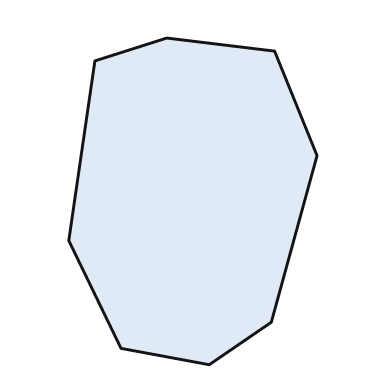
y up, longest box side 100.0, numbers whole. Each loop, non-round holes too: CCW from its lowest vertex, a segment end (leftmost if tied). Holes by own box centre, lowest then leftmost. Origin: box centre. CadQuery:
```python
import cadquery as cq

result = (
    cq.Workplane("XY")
    .moveTo(5.0, -50.0)
    .lineTo(24.0, -37.0)
    .lineTo(38.0, 14.0)
    .lineTo(25.0, 46.0)
    .lineTo(-8.0, 50.0)
    .lineTo(-30.0, 43.0)
    .lineTo(-38.0, -12.0)
    .lineTo(-22.0, -45.0)
    .close()
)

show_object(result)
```